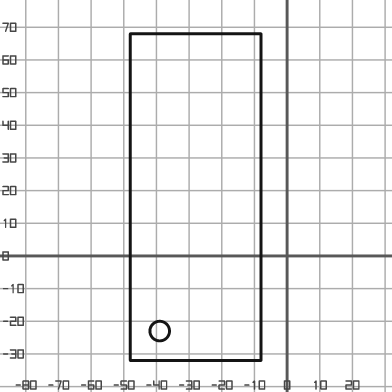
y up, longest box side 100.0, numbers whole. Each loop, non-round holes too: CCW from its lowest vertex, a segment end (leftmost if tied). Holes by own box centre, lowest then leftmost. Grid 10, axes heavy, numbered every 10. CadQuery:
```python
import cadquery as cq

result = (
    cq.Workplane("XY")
    .moveTo(-48.0, -32.0)
    .lineTo(-8.0, -32.0)
    .lineTo(-8.0, 68.0)
    .lineTo(-48.0, 68.0)
    .close()
    .moveTo(-39.0, -23.0)
    .circle(3.0)
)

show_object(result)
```